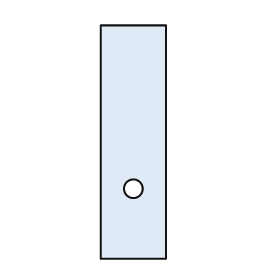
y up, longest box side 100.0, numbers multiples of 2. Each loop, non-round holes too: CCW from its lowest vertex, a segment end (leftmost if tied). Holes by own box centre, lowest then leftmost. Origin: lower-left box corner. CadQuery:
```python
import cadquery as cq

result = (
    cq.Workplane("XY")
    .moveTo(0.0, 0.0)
    .lineTo(28.0, 0.0)
    .lineTo(28.0, 100.0)
    .lineTo(0.0, 100.0)
    .close()
    .moveTo(14.0, 30.0)
    .circle(4.0)
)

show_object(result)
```